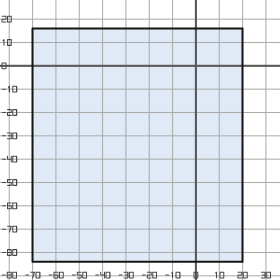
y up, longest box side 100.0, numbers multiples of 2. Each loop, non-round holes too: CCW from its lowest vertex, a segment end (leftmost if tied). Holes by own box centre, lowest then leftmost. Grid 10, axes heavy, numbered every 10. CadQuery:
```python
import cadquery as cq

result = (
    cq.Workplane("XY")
    .moveTo(-70.0, -84.0)
    .lineTo(20.0, -84.0)
    .lineTo(20.0, 16.0)
    .lineTo(-70.0, 16.0)
    .close()
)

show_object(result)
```